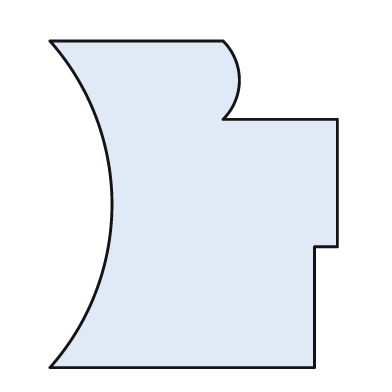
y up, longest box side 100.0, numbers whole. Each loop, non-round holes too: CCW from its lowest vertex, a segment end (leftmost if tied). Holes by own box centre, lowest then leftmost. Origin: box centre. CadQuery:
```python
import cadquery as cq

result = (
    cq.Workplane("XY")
    .moveTo(-44.0, -50.0)
    .lineTo(37.0, -50.0)
    .lineTo(37.0, -13.0)
    .lineTo(44.0, -13.0)
    .lineTo(44.0, 26.0)
    .lineTo(9.0, 26.0)
    .threePointArc((14.0, 38.0), (9.0, 50.0))
    .lineTo(-44.0, 50.0)
    .threePointArc((-25.0, 0.0), (-44.0, -50.0))
    .close()
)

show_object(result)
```